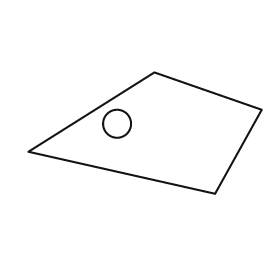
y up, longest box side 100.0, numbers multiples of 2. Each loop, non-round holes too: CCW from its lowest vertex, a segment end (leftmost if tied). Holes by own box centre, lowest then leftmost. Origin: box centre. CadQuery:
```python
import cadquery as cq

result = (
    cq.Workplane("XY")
    .moveTo(30.0, -26.0)
    .lineTo(50.0, 10.0)
    .lineTo(4.0, 26.0)
    .lineTo(-50.0, -8.0)
    .close()
    .moveTo(-12.0, 4.0)
    .circle(6.0)
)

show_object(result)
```